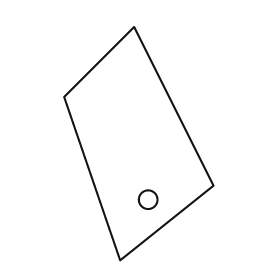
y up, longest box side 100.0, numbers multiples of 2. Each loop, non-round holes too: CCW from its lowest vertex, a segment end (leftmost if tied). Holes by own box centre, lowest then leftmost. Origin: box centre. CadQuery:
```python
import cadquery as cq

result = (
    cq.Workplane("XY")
    .moveTo(-8.0, -50.0)
    .lineTo(32.0, -18.0)
    .lineTo(-2.0, 50.0)
    .lineTo(-32.0, 20.0)
    .close()
    .moveTo(4.0, -24.0)
    .circle(4.0)
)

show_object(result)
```